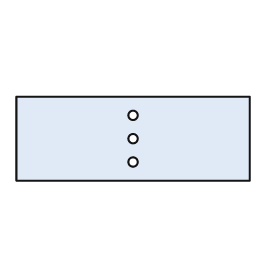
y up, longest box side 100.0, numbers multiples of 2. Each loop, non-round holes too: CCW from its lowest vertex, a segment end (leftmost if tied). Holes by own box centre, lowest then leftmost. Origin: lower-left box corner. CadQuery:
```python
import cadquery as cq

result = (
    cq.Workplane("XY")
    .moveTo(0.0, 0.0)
    .lineTo(100.0, 0.0)
    .lineTo(100.0, 36.0)
    .lineTo(0.0, 36.0)
    .close()
    .moveTo(50.0, 8.0)
    .circle(2.0)
    .moveTo(50.0, 18.0)
    .circle(2.0)
    .moveTo(50.0, 28.0)
    .circle(2.0)
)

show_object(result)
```